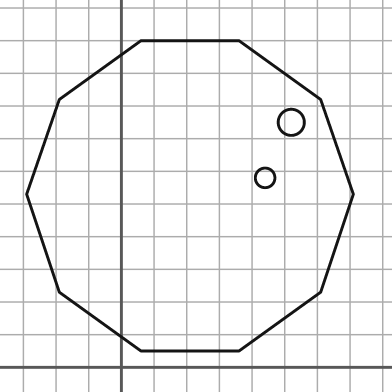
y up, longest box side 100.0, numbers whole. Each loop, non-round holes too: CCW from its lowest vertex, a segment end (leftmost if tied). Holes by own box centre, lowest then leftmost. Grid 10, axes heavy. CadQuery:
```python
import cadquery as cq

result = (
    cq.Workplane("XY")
    .moveTo(6.0, 5.0)
    .lineTo(36.0, 5.0)
    .lineTo(61.0, 23.0)
    .lineTo(71.0, 53.0)
    .lineTo(61.0, 82.0)
    .lineTo(36.0, 100.0)
    .lineTo(6.0, 100.0)
    .lineTo(-19.0, 82.0)
    .lineTo(-29.0, 53.0)
    .lineTo(-19.0, 23.0)
    .close()
    .moveTo(44.0, 58.0)
    .circle(3.0)
    .moveTo(52.0, 75.0)
    .circle(4.0)
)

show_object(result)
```